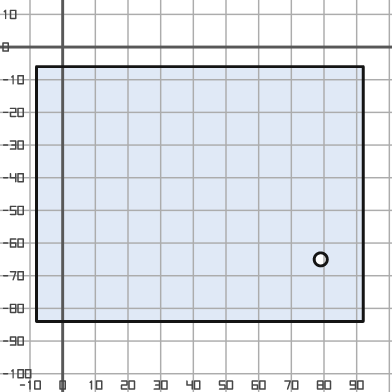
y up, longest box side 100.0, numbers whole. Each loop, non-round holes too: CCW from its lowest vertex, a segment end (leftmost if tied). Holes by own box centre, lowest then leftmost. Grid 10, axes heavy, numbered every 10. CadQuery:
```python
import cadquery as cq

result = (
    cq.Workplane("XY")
    .moveTo(-8.0, -84.0)
    .lineTo(92.0, -84.0)
    .lineTo(92.0, -6.0)
    .lineTo(-8.0, -6.0)
    .close()
    .moveTo(79.0, -65.0)
    .circle(2.0)
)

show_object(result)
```